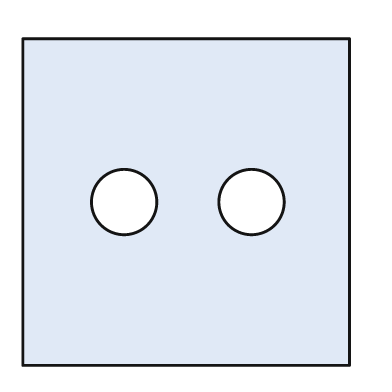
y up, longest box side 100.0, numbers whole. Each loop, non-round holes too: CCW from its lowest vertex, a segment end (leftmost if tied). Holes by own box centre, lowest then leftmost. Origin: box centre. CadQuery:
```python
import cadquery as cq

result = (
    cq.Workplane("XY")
    .moveTo(-50.0, -50.0)
    .lineTo(50.0, -50.0)
    .lineTo(50.0, 50.0)
    .lineTo(-50.0, 50.0)
    .close()
    .moveTo(-19.0, 0.0)
    .circle(10.0)
    .moveTo(20.0, 0.0)
    .circle(10.0)
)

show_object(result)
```